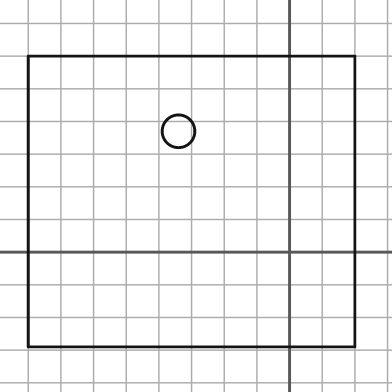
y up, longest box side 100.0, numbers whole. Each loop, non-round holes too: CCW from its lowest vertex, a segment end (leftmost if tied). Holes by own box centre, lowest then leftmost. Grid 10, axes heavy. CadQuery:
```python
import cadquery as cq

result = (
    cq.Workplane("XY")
    .moveTo(-80.0, -29.0)
    .lineTo(20.0, -29.0)
    .lineTo(20.0, 60.0)
    .lineTo(-80.0, 60.0)
    .close()
    .moveTo(-34.0, 37.0)
    .circle(5.0)
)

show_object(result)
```